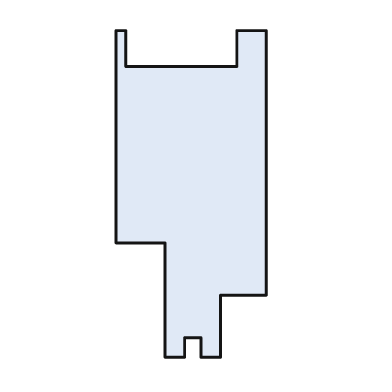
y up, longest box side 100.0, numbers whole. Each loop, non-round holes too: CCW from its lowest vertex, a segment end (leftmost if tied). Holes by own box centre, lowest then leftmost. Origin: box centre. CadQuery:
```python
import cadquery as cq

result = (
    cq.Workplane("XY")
    .moveTo(-8.0, -50.0)
    .lineTo(-2.0, -50.0)
    .lineTo(-2.0, -44.0)
    .lineTo(3.0, -44.0)
    .lineTo(3.0, -50.0)
    .lineTo(9.0, -50.0)
    .lineTo(9.0, -31.0)
    .lineTo(23.0, -31.0)
    .lineTo(23.0, 50.0)
    .lineTo(14.0, 50.0)
    .lineTo(14.0, 39.0)
    .lineTo(-20.0, 39.0)
    .lineTo(-20.0, 50.0)
    .lineTo(-23.0, 50.0)
    .lineTo(-23.0, -15.0)
    .lineTo(-8.0, -15.0)
    .close()
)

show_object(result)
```